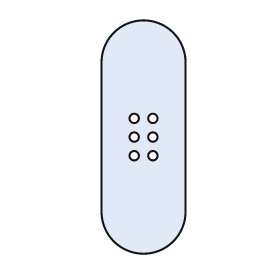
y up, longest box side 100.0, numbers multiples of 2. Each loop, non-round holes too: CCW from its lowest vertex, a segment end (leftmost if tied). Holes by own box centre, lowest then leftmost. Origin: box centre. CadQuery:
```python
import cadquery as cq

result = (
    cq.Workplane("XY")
    .moveTo(-18.0, -32.0)
    .threePointArc((0.0, -50.0), (18.0, -32.0))
    .lineTo(18.0, 32.0)
    .threePointArc((0.0, 50.0), (-18.0, 32.0))
    .close()
    .moveTo(-4.0, -8.0)
    .circle(2.0)
    .moveTo(4.0, -8.0)
    .circle(2.0)
    .moveTo(-4.0, 0.0)
    .circle(2.0)
    .moveTo(4.0, 0.0)
    .circle(2.0)
    .moveTo(-4.0, 8.0)
    .circle(2.0)
    .moveTo(4.0, 8.0)
    .circle(2.0)
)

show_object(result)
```